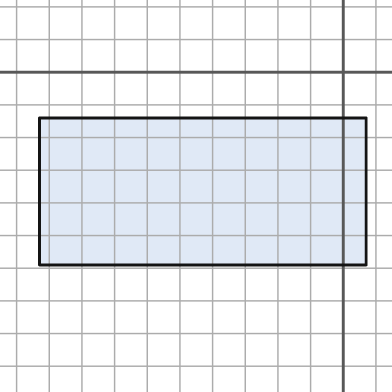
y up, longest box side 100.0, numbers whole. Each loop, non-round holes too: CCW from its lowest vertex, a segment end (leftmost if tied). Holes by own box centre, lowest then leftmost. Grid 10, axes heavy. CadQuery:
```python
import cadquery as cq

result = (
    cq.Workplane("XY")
    .moveTo(-93.0, -59.0)
    .lineTo(7.0, -59.0)
    .lineTo(7.0, -14.0)
    .lineTo(-93.0, -14.0)
    .close()
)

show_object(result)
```